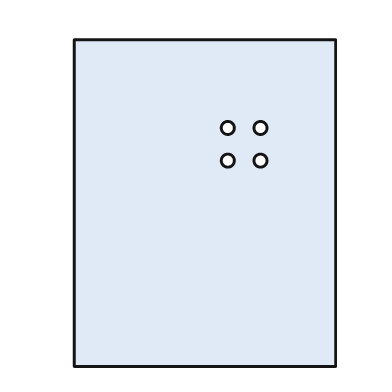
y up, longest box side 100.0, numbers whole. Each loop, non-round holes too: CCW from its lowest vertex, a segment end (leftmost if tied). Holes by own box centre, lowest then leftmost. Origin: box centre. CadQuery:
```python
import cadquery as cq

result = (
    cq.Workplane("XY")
    .moveTo(-40.0, -50.0)
    .lineTo(40.0, -50.0)
    .lineTo(40.0, 50.0)
    .lineTo(-40.0, 50.0)
    .close()
    .moveTo(7.0, 13.0)
    .circle(2.0)
    .moveTo(17.0, 13.0)
    .circle(2.0)
    .moveTo(7.0, 23.0)
    .circle(2.0)
    .moveTo(17.0, 23.0)
    .circle(2.0)
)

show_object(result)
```